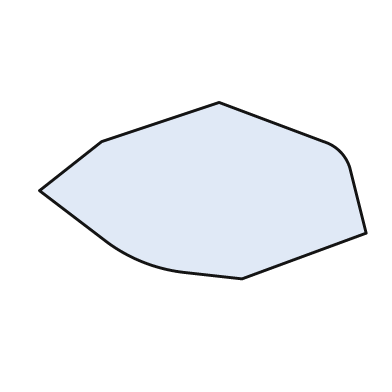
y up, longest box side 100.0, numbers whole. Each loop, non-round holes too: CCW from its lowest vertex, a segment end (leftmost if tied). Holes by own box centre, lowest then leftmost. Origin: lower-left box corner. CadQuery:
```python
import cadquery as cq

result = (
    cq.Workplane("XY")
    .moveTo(62.0, 0.0)
    .lineTo(100.0, 14.0)
    .lineTo(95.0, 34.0)
    .threePointArc((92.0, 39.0), (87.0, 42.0))
    .lineTo(55.0, 54.0)
    .lineTo(19.0, 42.0)
    .lineTo(0.0, 27.0)
    .lineTo(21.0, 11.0)
    .threePointArc((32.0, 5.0), (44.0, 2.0))
    .close()
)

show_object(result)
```